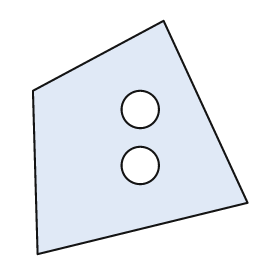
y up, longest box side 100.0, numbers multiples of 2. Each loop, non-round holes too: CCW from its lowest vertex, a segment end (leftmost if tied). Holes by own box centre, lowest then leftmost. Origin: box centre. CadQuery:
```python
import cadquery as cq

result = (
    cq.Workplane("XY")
    .moveTo(-44.0, -50.0)
    .lineTo(46.0, -28.0)
    .lineTo(10.0, 50.0)
    .lineTo(-46.0, 20.0)
    .close()
    .moveTo(0.0, -12.0)
    .circle(8.0)
    .moveTo(0.0, 12.0)
    .circle(8.0)
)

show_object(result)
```